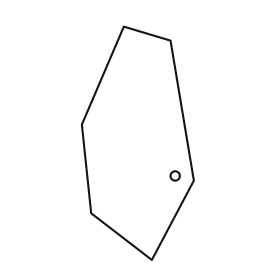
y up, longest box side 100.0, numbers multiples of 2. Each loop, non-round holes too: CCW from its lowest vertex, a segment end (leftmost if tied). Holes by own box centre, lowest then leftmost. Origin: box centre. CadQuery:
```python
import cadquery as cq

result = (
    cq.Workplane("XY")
    .moveTo(6.0, -50.0)
    .lineTo(24.0, -16.0)
    .lineTo(14.0, 44.0)
    .lineTo(-6.0, 50.0)
    .lineTo(-24.0, 8.0)
    .lineTo(-20.0, -30.0)
    .close()
    .moveTo(16.0, -14.0)
    .circle(2.0)
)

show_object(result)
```